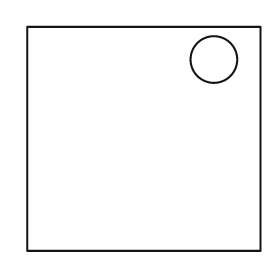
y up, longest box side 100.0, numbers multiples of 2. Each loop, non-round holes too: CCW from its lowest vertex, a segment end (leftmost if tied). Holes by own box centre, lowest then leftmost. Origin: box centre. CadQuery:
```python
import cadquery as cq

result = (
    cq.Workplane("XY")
    .moveTo(-50.0, -48.0)
    .lineTo(50.0, -48.0)
    .lineTo(50.0, 48.0)
    .lineTo(-50.0, 48.0)
    .close()
    .moveTo(30.0, 34.0)
    .circle(10.0)
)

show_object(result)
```